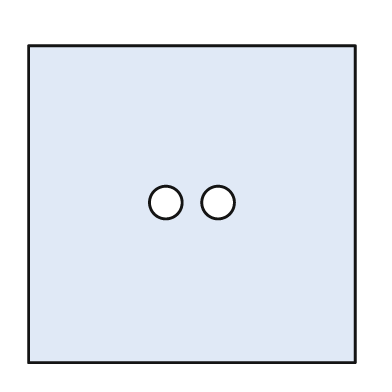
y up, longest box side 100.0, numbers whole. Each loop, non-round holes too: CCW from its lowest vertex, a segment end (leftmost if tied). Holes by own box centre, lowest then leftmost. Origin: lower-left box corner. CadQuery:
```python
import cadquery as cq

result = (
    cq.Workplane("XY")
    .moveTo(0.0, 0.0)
    .lineTo(100.0, 0.0)
    .lineTo(100.0, 97.0)
    .lineTo(0.0, 97.0)
    .close()
    .moveTo(42.0, 49.0)
    .circle(5.0)
    .moveTo(58.0, 49.0)
    .circle(5.0)
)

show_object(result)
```